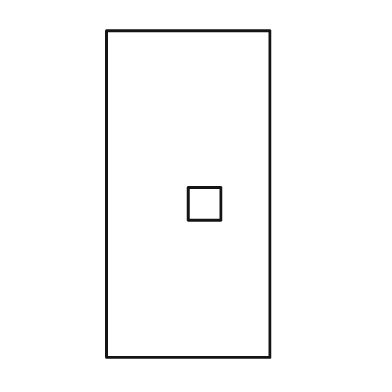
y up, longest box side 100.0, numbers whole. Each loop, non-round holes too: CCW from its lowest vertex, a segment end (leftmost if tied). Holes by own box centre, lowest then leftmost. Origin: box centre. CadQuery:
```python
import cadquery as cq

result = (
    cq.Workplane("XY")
    .moveTo(-25.0, -50.0)
    .lineTo(25.0, -50.0)
    .lineTo(25.0, 50.0)
    .lineTo(-25.0, 50.0)
    .close()
    .moveTo(0.0, -8.0)
    .lineTo(10.0, -8.0)
    .lineTo(10.0, 2.0)
    .lineTo(0.0, 2.0)
    .close()
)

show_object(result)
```